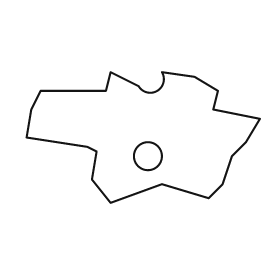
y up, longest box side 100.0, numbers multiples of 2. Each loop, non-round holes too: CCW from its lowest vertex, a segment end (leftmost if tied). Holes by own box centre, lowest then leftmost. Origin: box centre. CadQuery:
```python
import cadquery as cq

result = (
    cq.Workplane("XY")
    .moveTo(-14.0, -28.0)
    .lineTo(8.0, -20.0)
    .lineTo(28.0, -26.0)
    .lineTo(34.0, -20.0)
    .lineTo(38.0, -8.0)
    .lineTo(44.0, -2.0)
    .lineTo(50.0, 8.0)
    .lineTo(30.0, 12.0)
    .lineTo(32.0, 20.0)
    .lineTo(22.0, 26.0)
    .lineTo(8.0, 28.0)
    .threePointArc((6.0, 20.0), (-2.0, 22.0))
    .lineTo(-14.0, 28.0)
    .lineTo(-16.0, 20.0)
    .lineTo(-44.0, 20.0)
    .lineTo(-48.0, 12.0)
    .lineTo(-50.0, 0.0)
    .lineTo(-24.0, -4.0)
    .lineTo(-20.0, -6.0)
    .lineTo(-22.0, -18.0)
    .close()
    .moveTo(2.0, -8.0)
    .circle(6.0)
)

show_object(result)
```